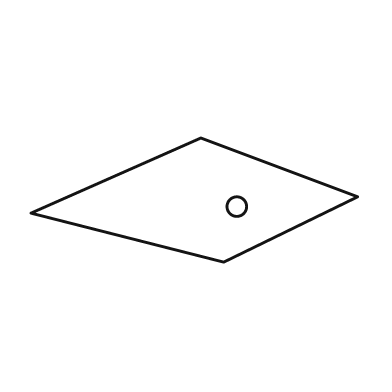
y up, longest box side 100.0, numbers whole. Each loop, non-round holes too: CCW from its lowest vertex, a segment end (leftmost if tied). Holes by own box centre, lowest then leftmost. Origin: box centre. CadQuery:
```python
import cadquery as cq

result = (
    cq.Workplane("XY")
    .moveTo(9.0, -19.0)
    .lineTo(50.0, 1.0)
    .lineTo(2.0, 19.0)
    .lineTo(-50.0, -4.0)
    .close()
    .moveTo(13.0, -2.0)
    .circle(3.0)
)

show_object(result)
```